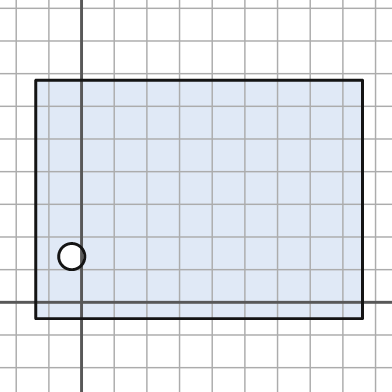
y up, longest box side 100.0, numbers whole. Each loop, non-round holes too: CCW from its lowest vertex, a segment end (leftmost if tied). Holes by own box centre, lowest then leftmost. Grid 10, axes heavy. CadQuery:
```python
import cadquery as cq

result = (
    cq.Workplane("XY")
    .moveTo(-14.0, -5.0)
    .lineTo(86.0, -5.0)
    .lineTo(86.0, 68.0)
    .lineTo(-14.0, 68.0)
    .close()
    .moveTo(-3.0, 14.0)
    .circle(4.0)
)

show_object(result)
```